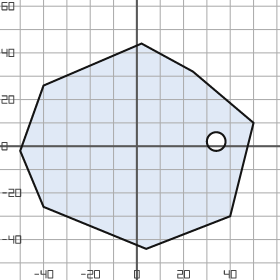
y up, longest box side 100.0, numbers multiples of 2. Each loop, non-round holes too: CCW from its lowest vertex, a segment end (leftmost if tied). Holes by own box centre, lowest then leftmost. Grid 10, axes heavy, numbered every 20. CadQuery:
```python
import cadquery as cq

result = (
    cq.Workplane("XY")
    .moveTo(4.0, -44.0)
    .lineTo(40.0, -30.0)
    .lineTo(50.0, 10.0)
    .lineTo(24.0, 32.0)
    .lineTo(2.0, 44.0)
    .lineTo(-40.0, 26.0)
    .lineTo(-50.0, -2.0)
    .lineTo(-40.0, -26.0)
    .close()
    .moveTo(34.0, 2.0)
    .circle(4.0)
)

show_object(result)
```